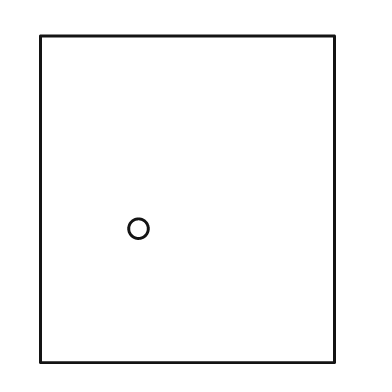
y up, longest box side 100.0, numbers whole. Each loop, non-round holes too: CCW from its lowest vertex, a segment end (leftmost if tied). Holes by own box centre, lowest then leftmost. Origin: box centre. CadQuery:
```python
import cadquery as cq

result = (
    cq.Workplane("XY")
    .moveTo(-45.0, -50.0)
    .lineTo(45.0, -50.0)
    .lineTo(45.0, 50.0)
    .lineTo(-45.0, 50.0)
    .close()
    .moveTo(-15.0, -9.0)
    .circle(3.0)
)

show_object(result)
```